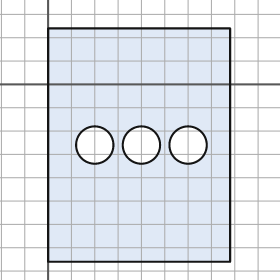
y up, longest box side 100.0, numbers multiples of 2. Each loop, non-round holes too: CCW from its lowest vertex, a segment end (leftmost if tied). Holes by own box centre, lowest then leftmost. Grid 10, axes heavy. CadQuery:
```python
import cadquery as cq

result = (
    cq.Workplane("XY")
    .moveTo(0.0, -76.0)
    .lineTo(78.0, -76.0)
    .lineTo(78.0, 24.0)
    .lineTo(0.0, 24.0)
    .close()
    .moveTo(20.0, -26.0)
    .circle(8.0)
    .moveTo(40.0, -26.0)
    .circle(8.0)
    .moveTo(60.0, -26.0)
    .circle(8.0)
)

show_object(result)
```